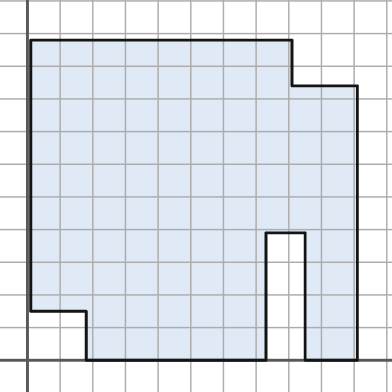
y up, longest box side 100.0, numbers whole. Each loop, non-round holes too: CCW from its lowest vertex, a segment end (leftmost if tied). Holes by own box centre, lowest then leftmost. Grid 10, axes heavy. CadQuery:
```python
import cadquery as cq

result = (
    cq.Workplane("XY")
    .moveTo(18.0, 0.0)
    .lineTo(73.0, 0.0)
    .lineTo(73.0, 39.0)
    .lineTo(85.0, 39.0)
    .lineTo(85.0, 0.0)
    .lineTo(101.0, 0.0)
    .lineTo(101.0, 84.0)
    .lineTo(81.0, 84.0)
    .lineTo(81.0, 98.0)
    .lineTo(1.0, 98.0)
    .lineTo(1.0, 15.0)
    .lineTo(18.0, 15.0)
    .close()
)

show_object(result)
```